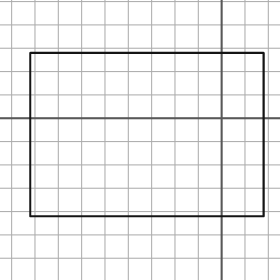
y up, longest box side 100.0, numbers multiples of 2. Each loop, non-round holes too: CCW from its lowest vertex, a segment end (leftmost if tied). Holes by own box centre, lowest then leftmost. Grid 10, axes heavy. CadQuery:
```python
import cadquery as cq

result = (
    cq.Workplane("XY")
    .moveTo(-82.0, -42.0)
    .lineTo(18.0, -42.0)
    .lineTo(18.0, 28.0)
    .lineTo(-82.0, 28.0)
    .close()
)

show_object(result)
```